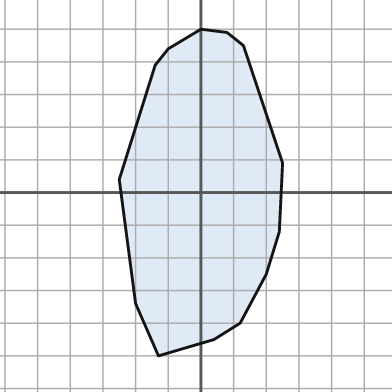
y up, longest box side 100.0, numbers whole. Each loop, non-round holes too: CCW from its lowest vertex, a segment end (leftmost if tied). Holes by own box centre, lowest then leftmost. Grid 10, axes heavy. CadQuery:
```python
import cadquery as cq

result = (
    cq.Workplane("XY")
    .moveTo(-13.0, -50.0)
    .lineTo(4.0, -45.0)
    .lineTo(12.0, -40.0)
    .lineTo(20.0, -25.0)
    .lineTo(24.0, -12.0)
    .lineTo(25.0, 9.0)
    .lineTo(13.0, 45.0)
    .lineTo(8.0, 49.0)
    .lineTo(0.0, 50.0)
    .lineTo(-10.0, 44.0)
    .lineTo(-14.0, 39.0)
    .lineTo(-25.0, 4.0)
    .lineTo(-20.0, -34.0)
    .close()
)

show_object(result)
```